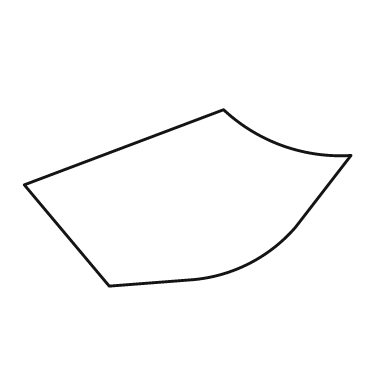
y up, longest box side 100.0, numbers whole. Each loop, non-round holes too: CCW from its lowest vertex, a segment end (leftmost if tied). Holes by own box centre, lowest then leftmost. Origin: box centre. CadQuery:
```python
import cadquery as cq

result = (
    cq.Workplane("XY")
    .moveTo(-24.0, -27.0)
    .lineTo(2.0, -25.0)
    .threePointArc((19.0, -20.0), (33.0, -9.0))
    .lineTo(50.0, 13.0)
    .threePointArc((29.0, 16.0), (11.0, 27.0))
    .lineTo(-50.0, 4.0)
    .close()
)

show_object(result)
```